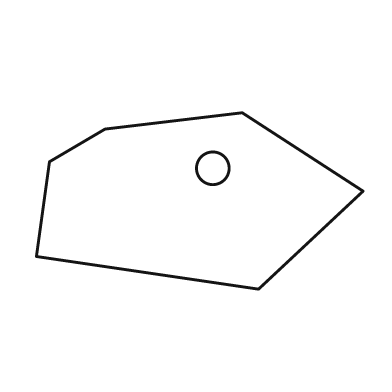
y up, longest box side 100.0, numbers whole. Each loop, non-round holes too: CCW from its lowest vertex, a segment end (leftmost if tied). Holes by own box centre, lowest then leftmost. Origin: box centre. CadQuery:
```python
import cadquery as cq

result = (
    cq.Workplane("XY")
    .moveTo(18.0, -27.0)
    .lineTo(50.0, 3.0)
    .lineTo(13.0, 27.0)
    .lineTo(-29.0, 22.0)
    .lineTo(-46.0, 12.0)
    .lineTo(-50.0, -17.0)
    .close()
    .moveTo(4.0, 10.0)
    .circle(5.0)
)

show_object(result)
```